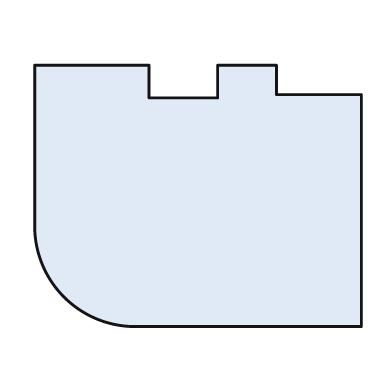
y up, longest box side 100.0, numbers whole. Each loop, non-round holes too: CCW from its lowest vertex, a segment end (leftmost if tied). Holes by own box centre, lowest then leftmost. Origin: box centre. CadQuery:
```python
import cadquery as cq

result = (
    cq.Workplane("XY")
    .moveTo(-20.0, -40.0)
    .lineTo(50.0, -40.0)
    .lineTo(50.0, 31.0)
    .lineTo(24.0, 31.0)
    .lineTo(24.0, 40.0)
    .lineTo(6.0, 40.0)
    .lineTo(6.0, 30.0)
    .lineTo(-15.0, 30.0)
    .lineTo(-15.0, 40.0)
    .lineTo(-50.0, 40.0)
    .lineTo(-50.0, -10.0)
    .threePointArc((-41.0, -31.0), (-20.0, -40.0))
    .close()
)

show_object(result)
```